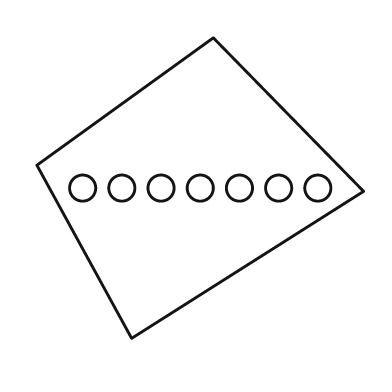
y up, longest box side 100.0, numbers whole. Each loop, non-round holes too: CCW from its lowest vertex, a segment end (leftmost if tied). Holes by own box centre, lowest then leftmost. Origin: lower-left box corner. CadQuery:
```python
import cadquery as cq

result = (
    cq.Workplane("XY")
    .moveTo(29.0, 0.0)
    .lineTo(100.0, 45.0)
    .lineTo(54.0, 92.0)
    .lineTo(0.0, 53.0)
    .close()
    .moveTo(14.0, 46.0)
    .circle(4.0)
    .moveTo(26.0, 46.0)
    .circle(4.0)
    .moveTo(38.0, 46.0)
    .circle(4.0)
    .moveTo(50.0, 46.0)
    .circle(4.0)
    .moveTo(62.0, 46.0)
    .circle(4.0)
    .moveTo(74.0, 46.0)
    .circle(4.0)
    .moveTo(86.0, 46.0)
    .circle(4.0)
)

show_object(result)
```